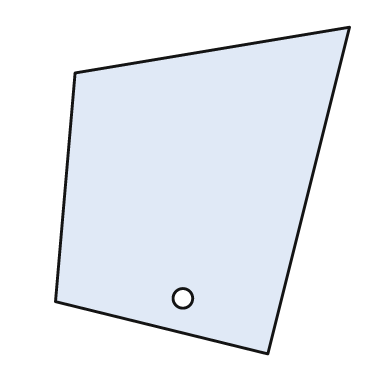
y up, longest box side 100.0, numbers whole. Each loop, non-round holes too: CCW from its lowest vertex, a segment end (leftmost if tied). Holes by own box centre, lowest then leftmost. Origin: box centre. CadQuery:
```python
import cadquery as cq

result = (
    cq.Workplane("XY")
    .moveTo(20.0, -50.0)
    .lineTo(45.0, 50.0)
    .lineTo(-39.0, 36.0)
    .lineTo(-45.0, -34.0)
    .close()
    .moveTo(-6.0, -33.0)
    .circle(3.0)
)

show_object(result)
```